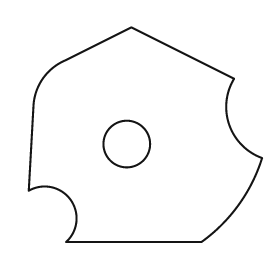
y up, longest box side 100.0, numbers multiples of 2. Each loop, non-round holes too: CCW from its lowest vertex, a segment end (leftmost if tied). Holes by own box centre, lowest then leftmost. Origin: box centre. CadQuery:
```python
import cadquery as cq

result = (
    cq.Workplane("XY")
    .moveTo(-34.0, -46.0)
    .lineTo(24.0, -46.0)
    .threePointArc((40.0, -30.0), (50.0, -10.0))
    .threePointArc((36.0, 4.0), (38.0, 24.0))
    .lineTo(-6.0, 46.0)
    .lineTo(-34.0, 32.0)
    .threePointArc((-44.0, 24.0), (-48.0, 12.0))
    .lineTo(-50.0, -24.0)
    .threePointArc((-32.0, -28.0), (-34.0, -46.0))
    .close()
    .moveTo(-8.0, -4.0)
    .circle(10.0)
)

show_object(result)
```